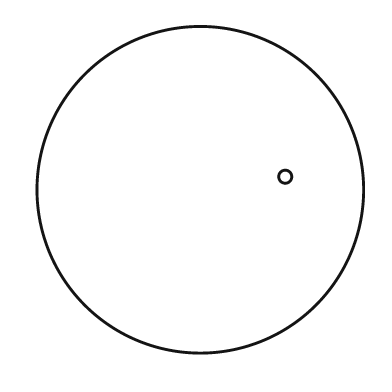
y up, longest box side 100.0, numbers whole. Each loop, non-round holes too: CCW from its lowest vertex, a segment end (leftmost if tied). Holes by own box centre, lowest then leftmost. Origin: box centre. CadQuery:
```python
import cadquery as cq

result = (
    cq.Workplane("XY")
    .moveTo(0.0, 0.0)
    .circle(50.0)
    .moveTo(26.0, 4.0)
    .circle(2.0)
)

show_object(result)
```